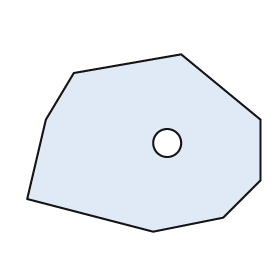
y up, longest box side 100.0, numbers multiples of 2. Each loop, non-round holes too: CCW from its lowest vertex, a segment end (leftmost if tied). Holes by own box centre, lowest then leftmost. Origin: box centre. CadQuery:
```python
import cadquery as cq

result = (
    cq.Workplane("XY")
    .moveTo(4.0, -38.0)
    .lineTo(34.0, -32.0)
    .lineTo(50.0, -16.0)
    .lineTo(50.0, 10.0)
    .lineTo(16.0, 38.0)
    .lineTo(-30.0, 30.0)
    .lineTo(-42.0, 10.0)
    .lineTo(-50.0, -24.0)
    .close()
    .moveTo(10.0, 0.0)
    .circle(6.0)
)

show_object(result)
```